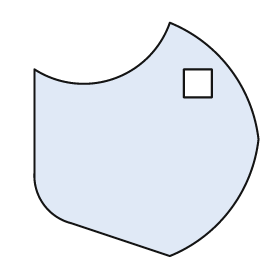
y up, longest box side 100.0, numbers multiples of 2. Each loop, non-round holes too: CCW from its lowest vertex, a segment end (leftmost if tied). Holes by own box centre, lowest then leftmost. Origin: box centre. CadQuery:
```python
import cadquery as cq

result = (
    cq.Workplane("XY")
    .moveTo(10.0, -50.0)
    .threePointArc((36.0, -30.0), (48.0, 0.0))
    .threePointArc((36.0, 30.0), (10.0, 50.0))
    .threePointArc((-14.0, 26.0), (-48.0, 30.0))
    .lineTo(-48.0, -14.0)
    .threePointArc((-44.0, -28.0), (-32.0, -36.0))
    .close()
    .moveTo(16.0, 18.0)
    .lineTo(28.0, 18.0)
    .lineTo(28.0, 30.0)
    .lineTo(16.0, 30.0)
    .close()
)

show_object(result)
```